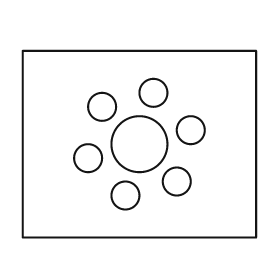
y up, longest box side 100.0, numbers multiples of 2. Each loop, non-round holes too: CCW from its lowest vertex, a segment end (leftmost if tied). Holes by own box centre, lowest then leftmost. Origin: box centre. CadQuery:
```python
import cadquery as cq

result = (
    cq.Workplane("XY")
    .moveTo(-50.0, -40.0)
    .lineTo(50.0, -40.0)
    .lineTo(50.0, 40.0)
    .lineTo(-50.0, 40.0)
    .close()
    .moveTo(-6.0, -22.0)
    .circle(6.0)
    .moveTo(16.0, -16.0)
    .circle(6.0)
    .moveTo(-22.0, -6.0)
    .circle(6.0)
    .moveTo(0.0, 0.0)
    .circle(12.0)
    .moveTo(22.0, 6.0)
    .circle(6.0)
    .moveTo(-16.0, 16.0)
    .circle(6.0)
    .moveTo(6.0, 22.0)
    .circle(6.0)
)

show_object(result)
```